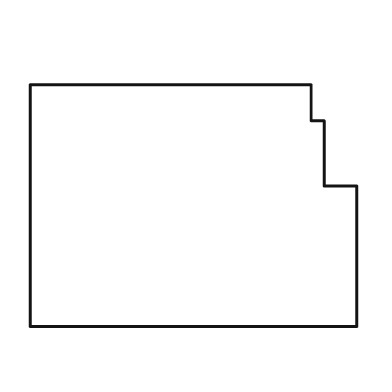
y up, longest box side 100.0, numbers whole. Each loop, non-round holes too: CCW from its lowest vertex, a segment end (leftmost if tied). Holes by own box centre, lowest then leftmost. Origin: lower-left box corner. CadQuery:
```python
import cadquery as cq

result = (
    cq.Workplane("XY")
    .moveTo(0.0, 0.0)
    .lineTo(100.0, 0.0)
    .lineTo(100.0, 43.0)
    .lineTo(90.0, 43.0)
    .lineTo(90.0, 63.0)
    .lineTo(86.0, 63.0)
    .lineTo(86.0, 74.0)
    .lineTo(0.0, 74.0)
    .close()
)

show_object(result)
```